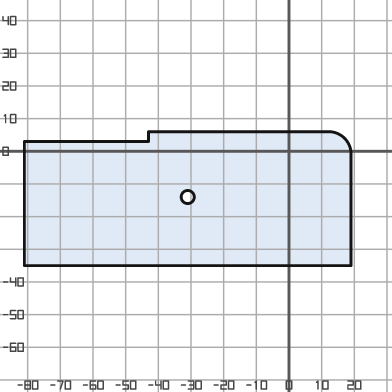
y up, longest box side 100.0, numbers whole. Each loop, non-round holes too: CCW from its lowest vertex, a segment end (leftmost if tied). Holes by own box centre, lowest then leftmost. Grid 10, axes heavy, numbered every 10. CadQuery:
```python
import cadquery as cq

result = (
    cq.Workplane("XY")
    .moveTo(-81.0, -35.0)
    .lineTo(19.0, -35.0)
    .lineTo(19.0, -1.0)
    .threePointArc((17.0, 4.0), (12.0, 6.0))
    .lineTo(-43.0, 6.0)
    .lineTo(-43.0, 3.0)
    .lineTo(-81.0, 3.0)
    .close()
    .moveTo(-31.0, -14.0)
    .circle(2.0)
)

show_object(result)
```